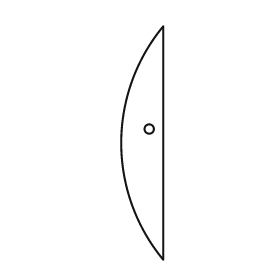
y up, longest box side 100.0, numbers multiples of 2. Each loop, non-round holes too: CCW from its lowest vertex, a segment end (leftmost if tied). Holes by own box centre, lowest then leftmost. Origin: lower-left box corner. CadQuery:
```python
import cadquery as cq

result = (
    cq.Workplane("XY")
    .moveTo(18.0, 0.0)
    .lineTo(18.0, 100.0)
    .threePointArc((0.0, 50.0), (18.0, 0.0))
    .close()
    .moveTo(12.0, 56.0)
    .circle(2.0)
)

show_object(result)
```